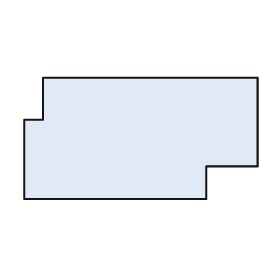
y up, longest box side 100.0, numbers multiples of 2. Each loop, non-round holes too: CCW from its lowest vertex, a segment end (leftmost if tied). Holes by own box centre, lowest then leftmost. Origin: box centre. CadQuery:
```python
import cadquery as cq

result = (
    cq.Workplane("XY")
    .moveTo(-50.0, -26.0)
    .lineTo(28.0, -26.0)
    .lineTo(28.0, -12.0)
    .lineTo(50.0, -12.0)
    .lineTo(50.0, 26.0)
    .lineTo(-42.0, 26.0)
    .lineTo(-42.0, 8.0)
    .lineTo(-50.0, 8.0)
    .close()
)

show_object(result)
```